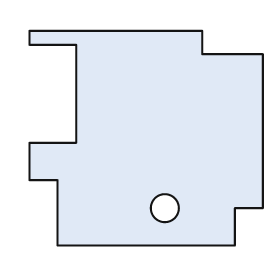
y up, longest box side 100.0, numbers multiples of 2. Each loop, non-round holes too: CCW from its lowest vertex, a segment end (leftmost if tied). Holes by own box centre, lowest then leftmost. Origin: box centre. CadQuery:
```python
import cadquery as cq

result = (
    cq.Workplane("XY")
    .moveTo(-38.0, -46.0)
    .lineTo(38.0, -46.0)
    .lineTo(38.0, -30.0)
    .lineTo(50.0, -30.0)
    .lineTo(50.0, 36.0)
    .lineTo(24.0, 36.0)
    .lineTo(24.0, 46.0)
    .lineTo(-50.0, 46.0)
    .lineTo(-50.0, 40.0)
    .lineTo(-30.0, 40.0)
    .lineTo(-30.0, -2.0)
    .lineTo(-50.0, -2.0)
    .lineTo(-50.0, -18.0)
    .lineTo(-38.0, -18.0)
    .close()
    .moveTo(8.0, -30.0)
    .circle(6.0)
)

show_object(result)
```